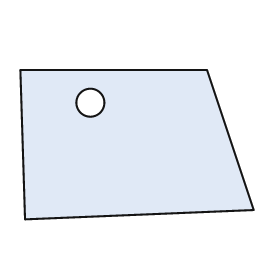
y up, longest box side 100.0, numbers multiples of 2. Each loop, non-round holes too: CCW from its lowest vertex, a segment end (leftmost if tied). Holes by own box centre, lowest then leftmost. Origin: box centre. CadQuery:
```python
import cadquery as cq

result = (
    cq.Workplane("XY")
    .moveTo(-48.0, -32.0)
    .lineTo(50.0, -28.0)
    .lineTo(30.0, 32.0)
    .lineTo(-50.0, 32.0)
    .close()
    .moveTo(-20.0, 18.0)
    .circle(6.0)
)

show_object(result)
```